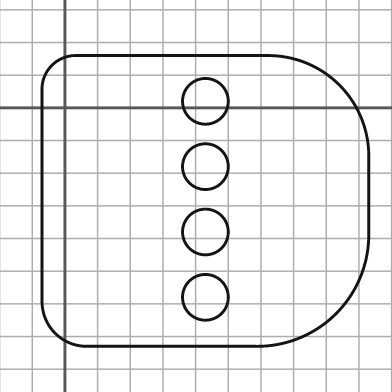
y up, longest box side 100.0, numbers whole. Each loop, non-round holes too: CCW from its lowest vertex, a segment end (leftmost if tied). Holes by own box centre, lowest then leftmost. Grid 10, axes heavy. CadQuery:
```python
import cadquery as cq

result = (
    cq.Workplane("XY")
    .moveTo(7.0, -73.0)
    .lineTo(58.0, -73.0)
    .threePointArc((83.0, -63.0), (93.0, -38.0))
    .lineTo(93.0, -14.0)
    .threePointArc((84.0, 7.0), (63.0, 16.0))
    .lineTo(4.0, 16.0)
    .threePointArc((-4.0, 13.0), (-7.0, 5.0))
    .lineTo(-7.0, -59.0)
    .threePointArc((-3.0, -69.0), (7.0, -73.0))
    .close()
    .moveTo(43.0, -58.0)
    .circle(7.0)
    .moveTo(43.0, -38.0)
    .circle(7.0)
    .moveTo(43.0, -18.0)
    .circle(7.0)
    .moveTo(43.0, 2.0)
    .circle(7.0)
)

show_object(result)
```